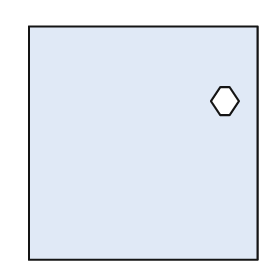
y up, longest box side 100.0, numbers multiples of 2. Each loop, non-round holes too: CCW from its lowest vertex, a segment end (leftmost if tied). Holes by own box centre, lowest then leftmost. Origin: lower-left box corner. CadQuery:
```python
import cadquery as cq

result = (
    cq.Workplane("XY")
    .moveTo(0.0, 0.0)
    .lineTo(98.0, 0.0)
    .lineTo(98.0, 100.0)
    .lineTo(0.0, 100.0)
    .close()
    .moveTo(82.0, 62.0)
    .lineTo(86.0, 62.0)
    .lineTo(90.0, 68.0)
    .lineTo(86.0, 74.0)
    .lineTo(82.0, 74.0)
    .lineTo(78.0, 68.0)
    .close()
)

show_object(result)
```